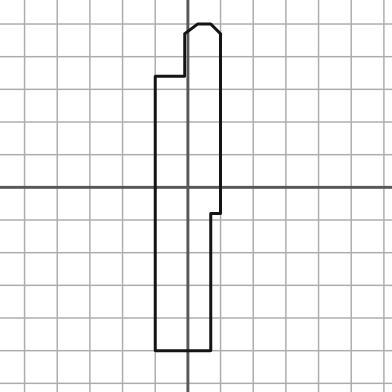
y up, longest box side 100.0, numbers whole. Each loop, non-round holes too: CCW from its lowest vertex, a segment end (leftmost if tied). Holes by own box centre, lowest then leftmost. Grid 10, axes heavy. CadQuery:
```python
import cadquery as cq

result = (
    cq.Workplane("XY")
    .moveTo(-10.0, -50.0)
    .lineTo(7.0, -50.0)
    .lineTo(7.0, -8.0)
    .lineTo(10.0, -8.0)
    .lineTo(10.0, 47.0)
    .lineTo(7.0, 50.0)
    .lineTo(3.0, 50.0)
    .lineTo(-1.0, 47.0)
    .lineTo(-1.0, 34.0)
    .lineTo(-10.0, 34.0)
    .close()
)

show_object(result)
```